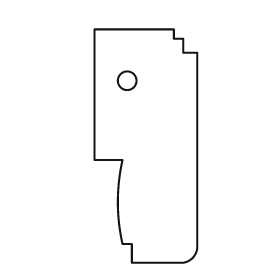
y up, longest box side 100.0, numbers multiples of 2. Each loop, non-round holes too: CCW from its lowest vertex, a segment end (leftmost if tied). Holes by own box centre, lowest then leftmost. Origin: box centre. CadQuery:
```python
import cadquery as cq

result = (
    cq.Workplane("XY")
    .moveTo(-6.0, -50.0)
    .lineTo(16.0, -50.0)
    .threePointArc((20.0, -48.0), (22.0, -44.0))
    .lineTo(22.0, 40.0)
    .lineTo(16.0, 40.0)
    .lineTo(16.0, 46.0)
    .lineTo(12.0, 46.0)
    .lineTo(12.0, 50.0)
    .lineTo(-22.0, 50.0)
    .lineTo(-22.0, -6.0)
    .lineTo(-10.0, -6.0)
    .threePointArc((-12.0, -24.0), (-10.0, -42.0))
    .lineTo(-6.0, -42.0)
    .close()
    .moveTo(-8.0, 28.0)
    .circle(4.0)
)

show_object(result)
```